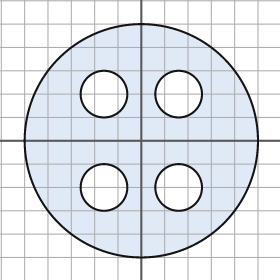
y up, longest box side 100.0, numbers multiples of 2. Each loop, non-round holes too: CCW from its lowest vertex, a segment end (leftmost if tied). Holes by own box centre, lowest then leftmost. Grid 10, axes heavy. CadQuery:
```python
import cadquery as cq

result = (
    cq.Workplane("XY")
    .moveTo(0.0, 0.0)
    .circle(50.0)
    .moveTo(-16.0, -20.0)
    .circle(10.0)
    .moveTo(16.0, -20.0)
    .circle(10.0)
    .moveTo(-16.0, 20.0)
    .circle(10.0)
    .moveTo(16.0, 20.0)
    .circle(10.0)
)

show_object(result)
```